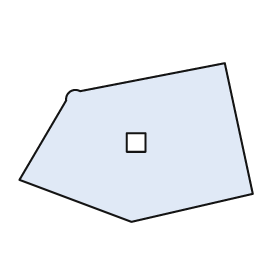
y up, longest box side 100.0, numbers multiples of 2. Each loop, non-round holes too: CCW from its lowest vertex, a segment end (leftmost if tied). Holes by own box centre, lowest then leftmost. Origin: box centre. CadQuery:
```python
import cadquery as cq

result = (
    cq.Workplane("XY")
    .moveTo(-2.0, -34.0)
    .lineTo(50.0, -22.0)
    .lineTo(38.0, 34.0)
    .lineTo(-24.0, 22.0)
    .threePointArc((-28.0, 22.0), (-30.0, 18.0))
    .lineTo(-50.0, -16.0)
    .close()
    .moveTo(-4.0, -4.0)
    .lineTo(4.0, -4.0)
    .lineTo(4.0, 4.0)
    .lineTo(-4.0, 4.0)
    .close()
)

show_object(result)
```